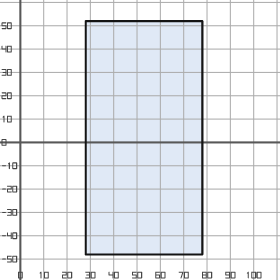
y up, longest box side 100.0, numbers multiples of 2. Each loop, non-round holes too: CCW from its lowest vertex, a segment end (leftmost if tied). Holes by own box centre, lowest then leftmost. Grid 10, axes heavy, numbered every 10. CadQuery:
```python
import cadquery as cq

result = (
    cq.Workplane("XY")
    .moveTo(28.0, -48.0)
    .lineTo(78.0, -48.0)
    .lineTo(78.0, 52.0)
    .lineTo(28.0, 52.0)
    .close()
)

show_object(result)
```